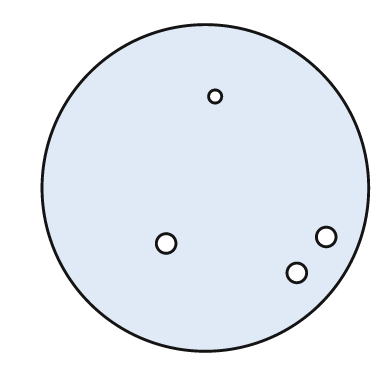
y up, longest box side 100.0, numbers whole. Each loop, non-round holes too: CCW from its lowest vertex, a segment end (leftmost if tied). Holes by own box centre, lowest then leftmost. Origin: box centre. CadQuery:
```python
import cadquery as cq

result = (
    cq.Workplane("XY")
    .moveTo(0.0, 0.0)
    .circle(50.0)
    .moveTo(28.0, -26.0)
    .circle(3.0)
    .moveTo(-12.0, -17.0)
    .circle(3.0)
    .moveTo(37.0, -15.0)
    .circle(3.0)
    .moveTo(3.0, 28.0)
    .circle(2.0)
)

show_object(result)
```